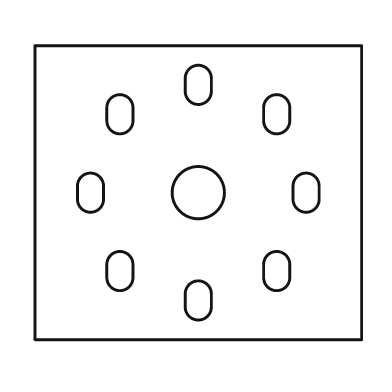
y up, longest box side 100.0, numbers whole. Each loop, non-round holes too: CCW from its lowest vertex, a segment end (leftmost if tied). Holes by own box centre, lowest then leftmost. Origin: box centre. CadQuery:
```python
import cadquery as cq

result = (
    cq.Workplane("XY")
    .moveTo(-50.0, -45.0)
    .lineTo(50.0, -45.0)
    .lineTo(50.0, 45.0)
    .lineTo(-50.0, 45.0)
    .close()
    .moveTo(-4.0, -35.0)
    .threePointArc((0.0, -39.0), (4.0, -35.0))
    .lineTo(4.0, -31.0)
    .threePointArc((0.0, -27.0), (-4.0, -31.0))
    .close()
    .moveTo(-28.0, -26.0)
    .threePointArc((-24.0, -30.0), (-20.0, -26.0))
    .lineTo(-20.0, -22.0)
    .threePointArc((-24.0, -18.0), (-28.0, -22.0))
    .close()
    .moveTo(20.0, -26.0)
    .threePointArc((24.0, -30.0), (28.0, -26.0))
    .lineTo(28.0, -22.0)
    .threePointArc((24.0, -18.0), (20.0, -22.0))
    .close()
    .moveTo(-37.0, -2.0)
    .threePointArc((-33.0, -6.0), (-29.0, -2.0))
    .lineTo(-29.0, 2.0)
    .threePointArc((-33.0, 6.0), (-37.0, 2.0))
    .close()
    .moveTo(0.0, 0.0)
    .circle(8.0)
    .moveTo(29.0, -2.0)
    .threePointArc((33.0, -6.0), (37.0, -2.0))
    .lineTo(37.0, 2.0)
    .threePointArc((33.0, 6.0), (29.0, 2.0))
    .close()
    .moveTo(-28.0, 22.0)
    .threePointArc((-24.0, 18.0), (-20.0, 22.0))
    .lineTo(-20.0, 26.0)
    .threePointArc((-24.0, 30.0), (-28.0, 26.0))
    .close()
    .moveTo(20.0, 22.0)
    .threePointArc((24.0, 18.0), (28.0, 22.0))
    .lineTo(28.0, 26.0)
    .threePointArc((24.0, 30.0), (20.0, 26.0))
    .close()
    .moveTo(-4.0, 31.0)
    .threePointArc((0.0, 27.0), (4.0, 31.0))
    .lineTo(4.0, 35.0)
    .threePointArc((0.0, 39.0), (-4.0, 35.0))
    .close()
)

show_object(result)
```